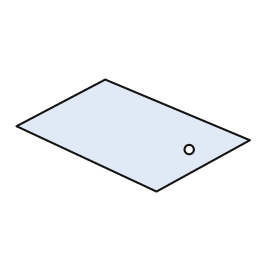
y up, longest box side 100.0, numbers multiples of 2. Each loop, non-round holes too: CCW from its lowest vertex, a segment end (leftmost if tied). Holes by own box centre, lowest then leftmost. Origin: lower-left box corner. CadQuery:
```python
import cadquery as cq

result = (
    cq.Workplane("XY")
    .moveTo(60.0, 0.0)
    .lineTo(100.0, 22.0)
    .lineTo(38.0, 48.0)
    .lineTo(0.0, 28.0)
    .close()
    .moveTo(74.0, 18.0)
    .circle(2.0)
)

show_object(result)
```